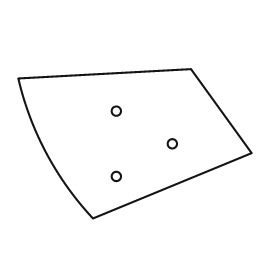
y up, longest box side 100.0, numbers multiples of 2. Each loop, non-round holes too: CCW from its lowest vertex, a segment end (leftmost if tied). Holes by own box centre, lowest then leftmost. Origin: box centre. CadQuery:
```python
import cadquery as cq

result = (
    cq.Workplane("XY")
    .moveTo(-18.0, -32.0)
    .lineTo(50.0, -4.0)
    .lineTo(24.0, 32.0)
    .lineTo(-50.0, 28.0)
    .threePointArc((-38.0, -4.0), (-18.0, -32.0))
    .close()
    .moveTo(-8.0, -14.0)
    .circle(2.0)
    .moveTo(16.0, 0.0)
    .circle(2.0)
    .moveTo(-8.0, 14.0)
    .circle(2.0)
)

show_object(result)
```